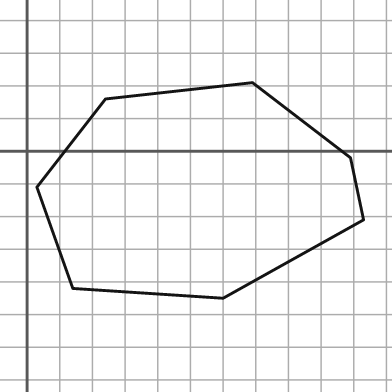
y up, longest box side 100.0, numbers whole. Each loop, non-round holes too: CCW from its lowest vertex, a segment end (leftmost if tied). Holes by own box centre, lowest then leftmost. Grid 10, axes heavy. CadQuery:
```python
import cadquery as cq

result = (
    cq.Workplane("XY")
    .moveTo(60.0, -45.0)
    .lineTo(103.0, -21.0)
    .lineTo(99.0, -2.0)
    .lineTo(69.0, 21.0)
    .lineTo(24.0, 16.0)
    .lineTo(3.0, -11.0)
    .lineTo(14.0, -42.0)
    .close()
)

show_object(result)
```